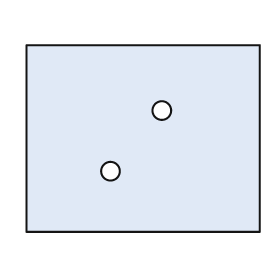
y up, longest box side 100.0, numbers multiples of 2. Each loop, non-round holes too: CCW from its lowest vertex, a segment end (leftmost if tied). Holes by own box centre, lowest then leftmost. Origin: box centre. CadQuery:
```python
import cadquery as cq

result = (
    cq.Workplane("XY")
    .moveTo(-50.0, -40.0)
    .lineTo(50.0, -40.0)
    .lineTo(50.0, 40.0)
    .lineTo(-50.0, 40.0)
    .close()
    .moveTo(-14.0, -14.0)
    .circle(4.0)
    .moveTo(8.0, 12.0)
    .circle(4.0)
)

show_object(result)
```